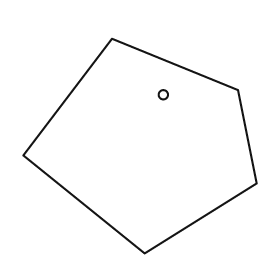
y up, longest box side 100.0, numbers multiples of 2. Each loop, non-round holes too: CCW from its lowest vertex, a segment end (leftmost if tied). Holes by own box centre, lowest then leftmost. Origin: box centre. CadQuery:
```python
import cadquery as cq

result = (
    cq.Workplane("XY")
    .moveTo(2.0, -46.0)
    .lineTo(50.0, -16.0)
    .lineTo(42.0, 24.0)
    .lineTo(-12.0, 46.0)
    .lineTo(-50.0, -4.0)
    .close()
    .moveTo(10.0, 22.0)
    .circle(2.0)
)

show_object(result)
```